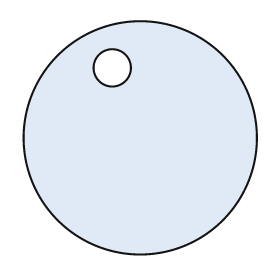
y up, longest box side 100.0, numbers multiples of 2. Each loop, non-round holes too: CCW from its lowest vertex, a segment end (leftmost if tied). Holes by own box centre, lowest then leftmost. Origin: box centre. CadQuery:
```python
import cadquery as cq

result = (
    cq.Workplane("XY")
    .moveTo(0.0, 0.0)
    .circle(50.0)
    .moveTo(-12.0, 30.0)
    .circle(8.0)
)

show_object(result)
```